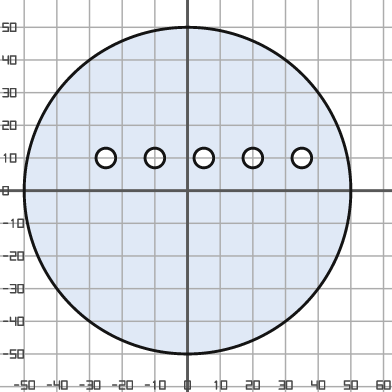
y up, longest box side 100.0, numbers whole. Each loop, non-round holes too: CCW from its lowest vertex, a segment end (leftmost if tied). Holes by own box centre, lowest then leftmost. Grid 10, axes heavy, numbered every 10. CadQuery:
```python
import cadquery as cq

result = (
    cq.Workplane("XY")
    .moveTo(0.0, 0.0)
    .circle(50.0)
    .moveTo(-25.0, 10.0)
    .circle(3.0)
    .moveTo(-10.0, 10.0)
    .circle(3.0)
    .moveTo(5.0, 10.0)
    .circle(3.0)
    .moveTo(20.0, 10.0)
    .circle(3.0)
    .moveTo(35.0, 10.0)
    .circle(3.0)
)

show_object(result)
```